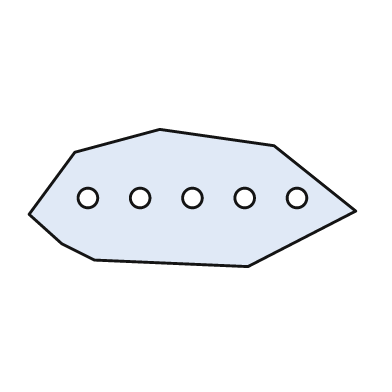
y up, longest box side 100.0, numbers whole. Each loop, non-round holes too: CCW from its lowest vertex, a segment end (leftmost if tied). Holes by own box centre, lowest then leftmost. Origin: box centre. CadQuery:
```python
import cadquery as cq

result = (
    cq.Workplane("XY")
    .moveTo(17.0, -21.0)
    .lineTo(50.0, -4.0)
    .lineTo(25.0, 16.0)
    .lineTo(-10.0, 21.0)
    .lineTo(-36.0, 14.0)
    .lineTo(-50.0, -5.0)
    .lineTo(-40.0, -14.0)
    .lineTo(-30.0, -19.0)
    .close()
    .moveTo(-32.0, 0.0)
    .circle(3.0)
    .moveTo(-16.0, 0.0)
    .circle(3.0)
    .moveTo(0.0, 0.0)
    .circle(3.0)
    .moveTo(16.0, 0.0)
    .circle(3.0)
    .moveTo(32.0, 0.0)
    .circle(3.0)
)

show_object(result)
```